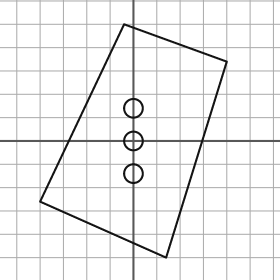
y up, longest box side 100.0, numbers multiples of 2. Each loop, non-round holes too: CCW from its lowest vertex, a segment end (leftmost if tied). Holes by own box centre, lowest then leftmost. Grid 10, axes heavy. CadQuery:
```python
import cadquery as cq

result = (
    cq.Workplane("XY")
    .moveTo(14.0, -50.0)
    .lineTo(40.0, 34.0)
    .lineTo(-4.0, 50.0)
    .lineTo(-40.0, -26.0)
    .close()
    .moveTo(0.0, -14.0)
    .circle(4.0)
    .moveTo(0.0, 0.0)
    .circle(4.0)
    .moveTo(0.0, 14.0)
    .circle(4.0)
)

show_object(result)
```